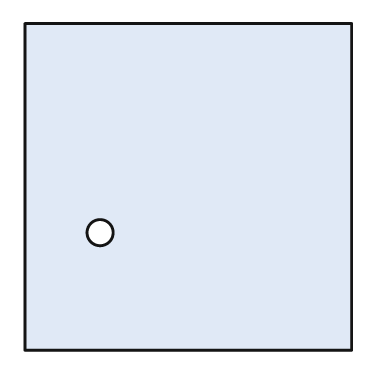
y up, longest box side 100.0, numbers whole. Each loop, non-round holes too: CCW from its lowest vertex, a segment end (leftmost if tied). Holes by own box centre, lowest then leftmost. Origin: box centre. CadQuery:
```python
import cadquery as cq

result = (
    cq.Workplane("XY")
    .moveTo(-50.0, -50.0)
    .lineTo(50.0, -50.0)
    .lineTo(50.0, 50.0)
    .lineTo(-50.0, 50.0)
    .close()
    .moveTo(-27.0, -14.0)
    .circle(4.0)
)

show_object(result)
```